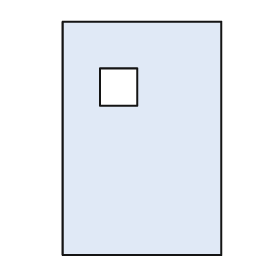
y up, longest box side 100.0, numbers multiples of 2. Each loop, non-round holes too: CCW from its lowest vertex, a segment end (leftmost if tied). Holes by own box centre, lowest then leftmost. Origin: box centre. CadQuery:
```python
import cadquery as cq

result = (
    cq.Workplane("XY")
    .moveTo(-34.0, -50.0)
    .lineTo(34.0, -50.0)
    .lineTo(34.0, 50.0)
    .lineTo(-34.0, 50.0)
    .close()
    .moveTo(-18.0, 14.0)
    .lineTo(-2.0, 14.0)
    .lineTo(-2.0, 30.0)
    .lineTo(-18.0, 30.0)
    .close()
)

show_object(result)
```